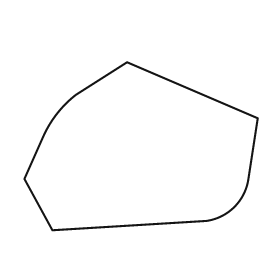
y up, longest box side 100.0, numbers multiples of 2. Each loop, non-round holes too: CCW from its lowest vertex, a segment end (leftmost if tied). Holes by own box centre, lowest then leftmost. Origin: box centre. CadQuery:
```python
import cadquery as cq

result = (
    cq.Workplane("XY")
    .moveTo(-38.0, -36.0)
    .lineTo(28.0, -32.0)
    .threePointArc((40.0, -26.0), (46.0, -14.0))
    .lineTo(50.0, 12.0)
    .lineTo(-6.0, 36.0)
    .lineTo(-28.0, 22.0)
    .threePointArc((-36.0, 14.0), (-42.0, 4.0))
    .lineTo(-50.0, -14.0)
    .close()
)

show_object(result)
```